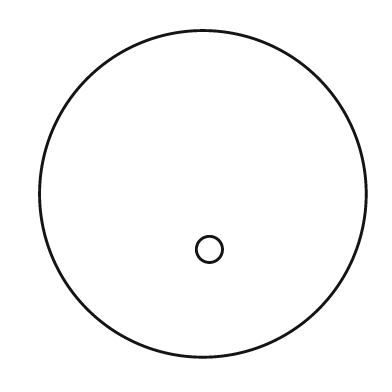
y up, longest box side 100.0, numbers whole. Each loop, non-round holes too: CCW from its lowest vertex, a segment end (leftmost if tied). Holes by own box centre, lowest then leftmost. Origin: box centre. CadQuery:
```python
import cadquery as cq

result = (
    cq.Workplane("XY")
    .moveTo(0.0, 0.0)
    .circle(50.0)
    .moveTo(2.0, -17.0)
    .circle(4.0)
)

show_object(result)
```